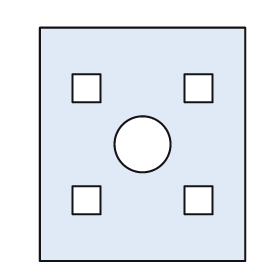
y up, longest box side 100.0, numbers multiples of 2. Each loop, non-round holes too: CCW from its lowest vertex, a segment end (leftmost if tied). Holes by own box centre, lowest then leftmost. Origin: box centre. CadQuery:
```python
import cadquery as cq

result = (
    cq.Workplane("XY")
    .moveTo(-44.0, -50.0)
    .lineTo(44.0, -50.0)
    .lineTo(44.0, 50.0)
    .lineTo(-44.0, 50.0)
    .close()
    .moveTo(-30.0, -30.0)
    .lineTo(-18.0, -30.0)
    .lineTo(-18.0, -18.0)
    .lineTo(-30.0, -18.0)
    .close()
    .moveTo(18.0, -30.0)
    .lineTo(30.0, -30.0)
    .lineTo(30.0, -18.0)
    .lineTo(18.0, -18.0)
    .close()
    .moveTo(0.0, 0.0)
    .circle(12.0)
    .moveTo(-30.0, 18.0)
    .lineTo(-18.0, 18.0)
    .lineTo(-18.0, 30.0)
    .lineTo(-30.0, 30.0)
    .close()
    .moveTo(18.0, 18.0)
    .lineTo(30.0, 18.0)
    .lineTo(30.0, 30.0)
    .lineTo(18.0, 30.0)
    .close()
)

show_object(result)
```